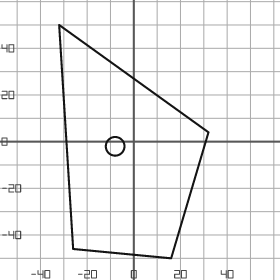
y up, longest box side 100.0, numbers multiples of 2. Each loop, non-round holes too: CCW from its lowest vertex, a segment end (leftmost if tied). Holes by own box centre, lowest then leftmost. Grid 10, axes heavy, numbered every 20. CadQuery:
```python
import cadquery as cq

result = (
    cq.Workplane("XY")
    .moveTo(16.0, -50.0)
    .lineTo(32.0, 4.0)
    .lineTo(-32.0, 50.0)
    .lineTo(-26.0, -46.0)
    .close()
    .moveTo(-8.0, -2.0)
    .circle(4.0)
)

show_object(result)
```